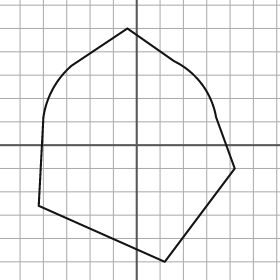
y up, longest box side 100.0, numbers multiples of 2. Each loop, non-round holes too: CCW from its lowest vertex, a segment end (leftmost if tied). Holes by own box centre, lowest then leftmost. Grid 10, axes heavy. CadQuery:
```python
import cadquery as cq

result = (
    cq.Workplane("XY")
    .moveTo(12.0, -50.0)
    .lineTo(42.0, -10.0)
    .lineTo(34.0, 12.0)
    .threePointArc((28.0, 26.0), (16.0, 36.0))
    .lineTo(-4.0, 50.0)
    .lineTo(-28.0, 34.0)
    .threePointArc((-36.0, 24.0), (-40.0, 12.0))
    .lineTo(-42.0, -26.0)
    .close()
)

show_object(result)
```